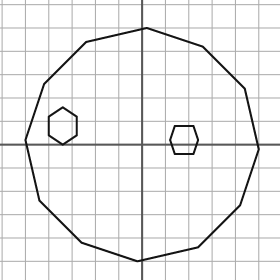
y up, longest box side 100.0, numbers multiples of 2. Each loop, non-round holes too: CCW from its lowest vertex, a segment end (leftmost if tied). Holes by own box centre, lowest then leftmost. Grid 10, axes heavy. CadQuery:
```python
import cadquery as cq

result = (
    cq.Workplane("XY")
    .moveTo(-2.0, -50.0)
    .lineTo(24.0, -44.0)
    .lineTo(42.0, -26.0)
    .lineTo(50.0, -2.0)
    .lineTo(44.0, 24.0)
    .lineTo(26.0, 42.0)
    .lineTo(2.0, 50.0)
    .lineTo(-24.0, 44.0)
    .lineTo(-42.0, 26.0)
    .lineTo(-50.0, 2.0)
    .lineTo(-44.0, -24.0)
    .lineTo(-26.0, -42.0)
    .close()
    .moveTo(14.0, -4.0)
    .lineTo(22.0, -4.0)
    .lineTo(24.0, 2.0)
    .lineTo(22.0, 8.0)
    .lineTo(14.0, 8.0)
    .lineTo(12.0, 2.0)
    .close()
    .moveTo(-34.0, 0.0)
    .lineTo(-28.0, 4.0)
    .lineTo(-28.0, 12.0)
    .lineTo(-34.0, 16.0)
    .lineTo(-40.0, 12.0)
    .lineTo(-40.0, 4.0)
    .close()
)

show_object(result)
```